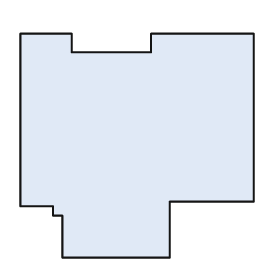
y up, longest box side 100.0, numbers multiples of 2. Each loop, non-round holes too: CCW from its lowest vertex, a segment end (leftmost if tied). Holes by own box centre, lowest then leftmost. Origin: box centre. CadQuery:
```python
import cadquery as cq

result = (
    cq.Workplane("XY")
    .moveTo(-32.0, -48.0)
    .lineTo(14.0, -48.0)
    .lineTo(14.0, -24.0)
    .lineTo(50.0, -24.0)
    .lineTo(50.0, 48.0)
    .lineTo(6.0, 48.0)
    .lineTo(6.0, 40.0)
    .lineTo(-28.0, 40.0)
    .lineTo(-28.0, 48.0)
    .lineTo(-50.0, 48.0)
    .lineTo(-50.0, -26.0)
    .lineTo(-36.0, -26.0)
    .lineTo(-36.0, -30.0)
    .lineTo(-32.0, -30.0)
    .close()
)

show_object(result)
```